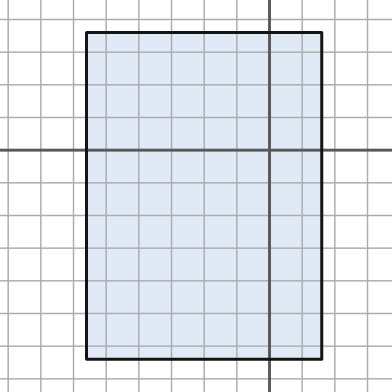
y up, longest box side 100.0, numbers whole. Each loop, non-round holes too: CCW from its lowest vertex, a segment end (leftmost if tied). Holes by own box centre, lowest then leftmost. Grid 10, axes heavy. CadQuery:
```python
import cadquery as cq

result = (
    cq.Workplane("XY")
    .moveTo(-56.0, -64.0)
    .lineTo(16.0, -64.0)
    .lineTo(16.0, 36.0)
    .lineTo(-56.0, 36.0)
    .close()
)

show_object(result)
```